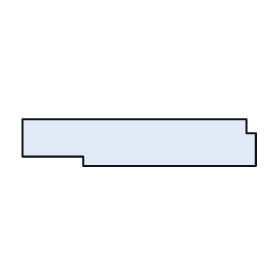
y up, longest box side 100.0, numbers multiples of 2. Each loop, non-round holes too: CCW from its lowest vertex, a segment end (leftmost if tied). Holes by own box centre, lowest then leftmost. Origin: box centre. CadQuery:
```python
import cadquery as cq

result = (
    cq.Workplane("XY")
    .moveTo(-24.0, -10.0)
    .lineTo(50.0, -10.0)
    .lineTo(50.0, 4.0)
    .lineTo(46.0, 4.0)
    .lineTo(46.0, 10.0)
    .lineTo(-50.0, 10.0)
    .lineTo(-50.0, -6.0)
    .lineTo(-24.0, -6.0)
    .close()
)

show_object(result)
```